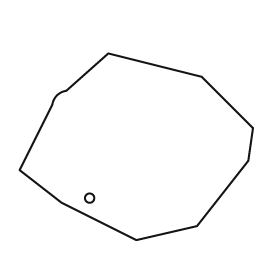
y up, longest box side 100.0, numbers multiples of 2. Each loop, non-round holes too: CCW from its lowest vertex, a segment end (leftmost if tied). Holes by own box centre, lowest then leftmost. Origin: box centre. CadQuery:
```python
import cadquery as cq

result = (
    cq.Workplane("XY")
    .moveTo(0.0, -40.0)
    .lineTo(26.0, -34.0)
    .lineTo(48.0, -6.0)
    .lineTo(50.0, 8.0)
    .lineTo(28.0, 30.0)
    .lineTo(-12.0, 40.0)
    .lineTo(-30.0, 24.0)
    .threePointArc((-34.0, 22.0), (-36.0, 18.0))
    .lineTo(-50.0, -10.0)
    .lineTo(-32.0, -24.0)
    .close()
    .moveTo(-20.0, -22.0)
    .circle(2.0)
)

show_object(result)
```